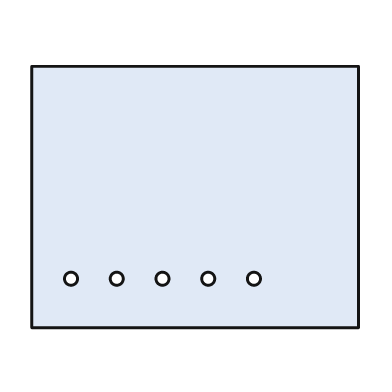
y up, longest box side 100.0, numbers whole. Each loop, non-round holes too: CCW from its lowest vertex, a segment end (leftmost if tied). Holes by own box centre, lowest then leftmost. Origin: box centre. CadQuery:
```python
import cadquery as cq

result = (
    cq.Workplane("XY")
    .moveTo(-50.0, -40.0)
    .lineTo(50.0, -40.0)
    .lineTo(50.0, 40.0)
    .lineTo(-50.0, 40.0)
    .close()
    .moveTo(-38.0, -25.0)
    .circle(2.0)
    .moveTo(-24.0, -25.0)
    .circle(2.0)
    .moveTo(-10.0, -25.0)
    .circle(2.0)
    .moveTo(4.0, -25.0)
    .circle(2.0)
    .moveTo(18.0, -25.0)
    .circle(2.0)
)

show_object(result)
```